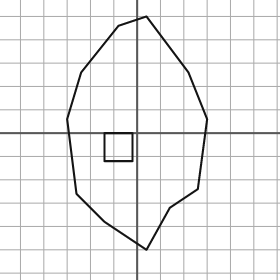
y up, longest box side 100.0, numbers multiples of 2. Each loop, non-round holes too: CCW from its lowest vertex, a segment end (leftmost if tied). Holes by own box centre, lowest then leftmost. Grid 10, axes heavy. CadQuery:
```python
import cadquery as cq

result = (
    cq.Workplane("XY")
    .moveTo(4.0, -50.0)
    .lineTo(14.0, -32.0)
    .lineTo(26.0, -24.0)
    .lineTo(30.0, 6.0)
    .lineTo(22.0, 26.0)
    .lineTo(4.0, 50.0)
    .lineTo(-8.0, 46.0)
    .lineTo(-24.0, 26.0)
    .lineTo(-30.0, 6.0)
    .lineTo(-26.0, -26.0)
    .lineTo(-14.0, -38.0)
    .close()
    .moveTo(-14.0, -12.0)
    .lineTo(-2.0, -12.0)
    .lineTo(-2.0, 0.0)
    .lineTo(-14.0, 0.0)
    .close()
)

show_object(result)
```